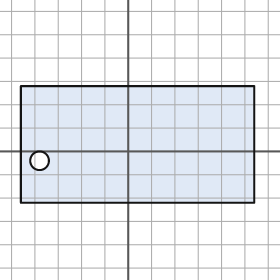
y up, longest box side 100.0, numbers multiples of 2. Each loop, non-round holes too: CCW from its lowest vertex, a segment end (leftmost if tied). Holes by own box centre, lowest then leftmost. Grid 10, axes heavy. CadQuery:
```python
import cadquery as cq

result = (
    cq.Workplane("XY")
    .moveTo(-46.0, -22.0)
    .lineTo(54.0, -22.0)
    .lineTo(54.0, 28.0)
    .lineTo(-46.0, 28.0)
    .close()
    .moveTo(-38.0, -4.0)
    .circle(4.0)
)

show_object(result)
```